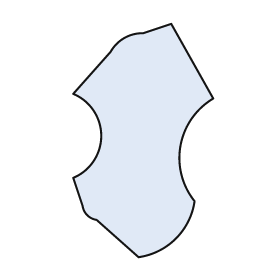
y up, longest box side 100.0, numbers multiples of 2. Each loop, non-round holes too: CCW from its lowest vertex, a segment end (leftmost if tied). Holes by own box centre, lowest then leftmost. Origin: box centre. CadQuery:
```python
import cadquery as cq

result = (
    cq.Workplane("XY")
    .moveTo(-2.0, -50.0)
    .threePointArc((14.0, -42.0), (22.0, -26.0))
    .threePointArc((16.0, -2.0), (30.0, 18.0))
    .lineTo(12.0, 50.0)
    .lineTo(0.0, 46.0)
    .threePointArc((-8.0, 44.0), (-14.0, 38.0))
    .lineTo(-30.0, 20.0)
    .threePointArc((-18.0, 2.0), (-30.0, -16.0))
    .lineTo(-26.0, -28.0)
    .threePointArc((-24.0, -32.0), (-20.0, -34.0))
    .close()
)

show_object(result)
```